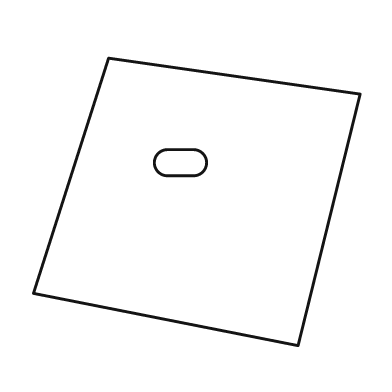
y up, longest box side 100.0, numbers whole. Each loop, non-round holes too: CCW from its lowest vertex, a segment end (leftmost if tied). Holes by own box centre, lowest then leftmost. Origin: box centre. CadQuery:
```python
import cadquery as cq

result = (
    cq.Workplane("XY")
    .moveTo(31.0, -44.0)
    .lineTo(50.0, 33.0)
    .lineTo(-27.0, 44.0)
    .lineTo(-50.0, -28.0)
    .close()
    .moveTo(-9.0, 8.0)
    .lineTo(-1.0, 8.0)
    .threePointArc((3.0, 12.0), (-1.0, 16.0))
    .lineTo(-9.0, 16.0)
    .threePointArc((-13.0, 12.0), (-9.0, 8.0))
    .close()
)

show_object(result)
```